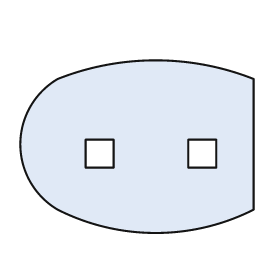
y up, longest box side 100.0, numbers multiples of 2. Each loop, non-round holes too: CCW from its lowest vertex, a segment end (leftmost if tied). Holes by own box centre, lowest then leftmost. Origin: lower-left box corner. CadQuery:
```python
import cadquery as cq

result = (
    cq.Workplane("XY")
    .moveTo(16.0, 10.0)
    .threePointArc((58.0, 0.0), (100.0, 10.0))
    .lineTo(100.0, 66.0)
    .threePointArc((58.0, 74.0), (16.0, 66.0))
    .threePointArc((0.0, 38.0), (16.0, 10.0))
    .close()
    .moveTo(28.0, 28.0)
    .lineTo(40.0, 28.0)
    .lineTo(40.0, 40.0)
    .lineTo(28.0, 40.0)
    .close()
    .moveTo(72.0, 28.0)
    .lineTo(84.0, 28.0)
    .lineTo(84.0, 40.0)
    .lineTo(72.0, 40.0)
    .close()
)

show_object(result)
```